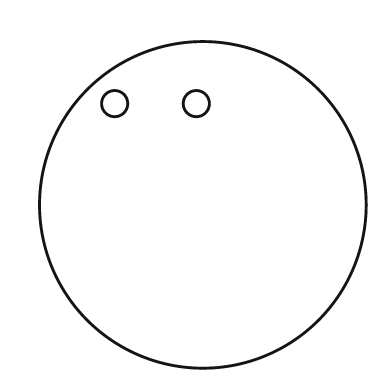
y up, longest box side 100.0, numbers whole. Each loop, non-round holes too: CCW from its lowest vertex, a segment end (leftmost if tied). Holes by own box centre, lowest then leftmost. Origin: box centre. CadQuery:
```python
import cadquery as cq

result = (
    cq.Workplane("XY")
    .moveTo(0.0, 0.0)
    .circle(50.0)
    .moveTo(-27.0, 31.0)
    .circle(4.0)
    .moveTo(-2.0, 31.0)
    .circle(4.0)
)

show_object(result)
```